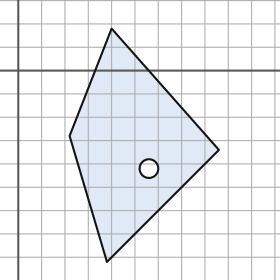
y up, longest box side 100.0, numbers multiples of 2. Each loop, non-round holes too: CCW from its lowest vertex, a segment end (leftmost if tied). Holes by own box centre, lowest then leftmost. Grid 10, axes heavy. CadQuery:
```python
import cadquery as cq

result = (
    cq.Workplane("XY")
    .moveTo(38.0, -82.0)
    .lineTo(86.0, -34.0)
    .lineTo(40.0, 18.0)
    .lineTo(22.0, -28.0)
    .close()
    .moveTo(56.0, -42.0)
    .circle(4.0)
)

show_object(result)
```